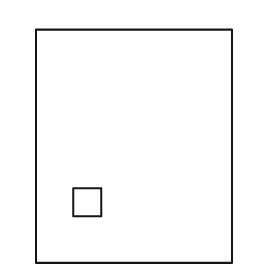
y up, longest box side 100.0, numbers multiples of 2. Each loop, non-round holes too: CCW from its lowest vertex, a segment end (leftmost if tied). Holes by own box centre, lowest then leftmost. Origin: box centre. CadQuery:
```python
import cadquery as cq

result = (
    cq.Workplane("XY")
    .moveTo(-42.0, -50.0)
    .lineTo(42.0, -50.0)
    .lineTo(42.0, 50.0)
    .lineTo(-42.0, 50.0)
    .close()
    .moveTo(-26.0, -30.0)
    .lineTo(-14.0, -30.0)
    .lineTo(-14.0, -18.0)
    .lineTo(-26.0, -18.0)
    .close()
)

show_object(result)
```